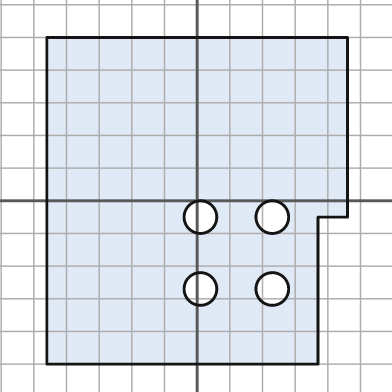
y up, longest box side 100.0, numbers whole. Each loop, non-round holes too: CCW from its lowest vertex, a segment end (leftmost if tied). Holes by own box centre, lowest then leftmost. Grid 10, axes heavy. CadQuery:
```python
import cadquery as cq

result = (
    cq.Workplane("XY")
    .moveTo(-46.0, -50.0)
    .lineTo(37.0, -50.0)
    .lineTo(37.0, -5.0)
    .lineTo(46.0, -5.0)
    .lineTo(46.0, 50.0)
    .lineTo(-46.0, 50.0)
    .close()
    .moveTo(1.0, -27.0)
    .circle(5.0)
    .moveTo(23.0, -27.0)
    .circle(5.0)
    .moveTo(1.0, -5.0)
    .circle(5.0)
    .moveTo(23.0, -5.0)
    .circle(5.0)
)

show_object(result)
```